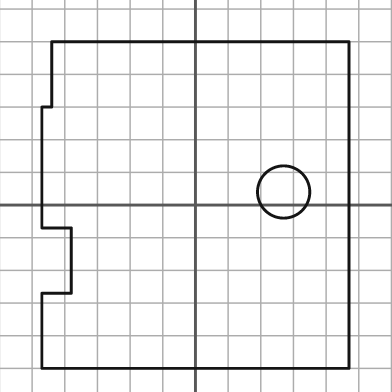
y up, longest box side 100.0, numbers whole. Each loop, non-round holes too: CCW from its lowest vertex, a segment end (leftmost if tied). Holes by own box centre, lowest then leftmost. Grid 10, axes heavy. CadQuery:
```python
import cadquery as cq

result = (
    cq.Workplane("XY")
    .moveTo(-47.0, -50.0)
    .lineTo(47.0, -50.0)
    .lineTo(47.0, 50.0)
    .lineTo(-44.0, 50.0)
    .lineTo(-44.0, 30.0)
    .lineTo(-47.0, 30.0)
    .lineTo(-47.0, -7.0)
    .lineTo(-38.0, -7.0)
    .lineTo(-38.0, -27.0)
    .lineTo(-47.0, -27.0)
    .close()
    .moveTo(27.0, 4.0)
    .circle(8.0)
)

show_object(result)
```